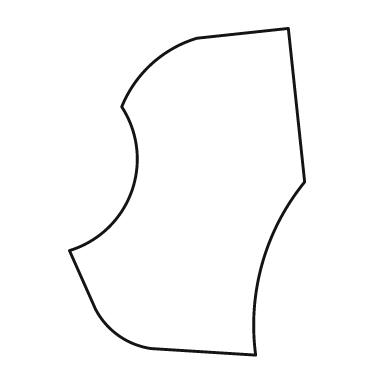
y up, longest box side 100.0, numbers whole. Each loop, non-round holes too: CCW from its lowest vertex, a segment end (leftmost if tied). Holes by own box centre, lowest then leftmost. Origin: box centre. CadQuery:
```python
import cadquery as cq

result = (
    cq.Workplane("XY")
    .moveTo(21.0, -50.0)
    .threePointArc((23.0, -22.0), (36.0, 3.0))
    .lineTo(31.0, 50.0)
    .lineTo(3.0, 47.0)
    .threePointArc((-11.0, 39.0), (-20.0, 26.0))
    .threePointArc((-17.0, 0.0), (-36.0, -18.0))
    .lineTo(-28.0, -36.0)
    .threePointArc((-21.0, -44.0), (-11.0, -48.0))
    .close()
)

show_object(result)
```